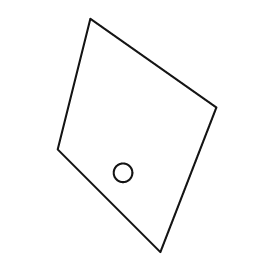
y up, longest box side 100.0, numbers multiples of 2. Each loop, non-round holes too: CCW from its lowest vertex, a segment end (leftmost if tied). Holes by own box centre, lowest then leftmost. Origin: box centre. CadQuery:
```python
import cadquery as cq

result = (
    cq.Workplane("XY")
    .moveTo(10.0, -50.0)
    .lineTo(34.0, 12.0)
    .lineTo(-20.0, 50.0)
    .lineTo(-34.0, -6.0)
    .close()
    .moveTo(-6.0, -16.0)
    .circle(4.0)
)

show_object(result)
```